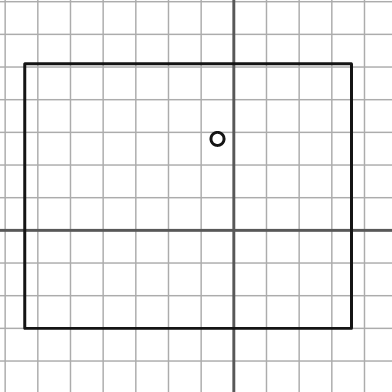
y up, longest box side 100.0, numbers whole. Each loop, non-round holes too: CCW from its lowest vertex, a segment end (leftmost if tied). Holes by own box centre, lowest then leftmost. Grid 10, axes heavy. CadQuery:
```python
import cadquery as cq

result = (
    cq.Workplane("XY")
    .moveTo(-64.0, -30.0)
    .lineTo(36.0, -30.0)
    .lineTo(36.0, 51.0)
    .lineTo(-64.0, 51.0)
    .close()
    .moveTo(-5.0, 28.0)
    .circle(2.0)
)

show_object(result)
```